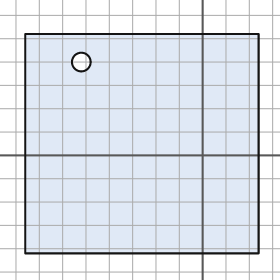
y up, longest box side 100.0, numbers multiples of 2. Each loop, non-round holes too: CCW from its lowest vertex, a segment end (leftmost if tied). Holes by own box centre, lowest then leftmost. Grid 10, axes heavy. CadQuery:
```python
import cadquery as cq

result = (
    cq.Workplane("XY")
    .moveTo(-76.0, -42.0)
    .lineTo(24.0, -42.0)
    .lineTo(24.0, 52.0)
    .lineTo(-76.0, 52.0)
    .close()
    .moveTo(-52.0, 40.0)
    .circle(4.0)
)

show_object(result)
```